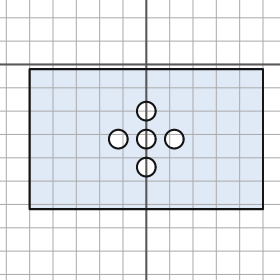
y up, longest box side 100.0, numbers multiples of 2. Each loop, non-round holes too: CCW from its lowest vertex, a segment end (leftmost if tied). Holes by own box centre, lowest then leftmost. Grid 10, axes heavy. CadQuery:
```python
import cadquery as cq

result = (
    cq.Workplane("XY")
    .moveTo(-50.0, -62.0)
    .lineTo(50.0, -62.0)
    .lineTo(50.0, -2.0)
    .lineTo(-50.0, -2.0)
    .close()
    .moveTo(0.0, -44.0)
    .circle(4.0)
    .moveTo(-12.0, -32.0)
    .circle(4.0)
    .moveTo(0.0, -32.0)
    .circle(4.0)
    .moveTo(12.0, -32.0)
    .circle(4.0)
    .moveTo(0.0, -20.0)
    .circle(4.0)
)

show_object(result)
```